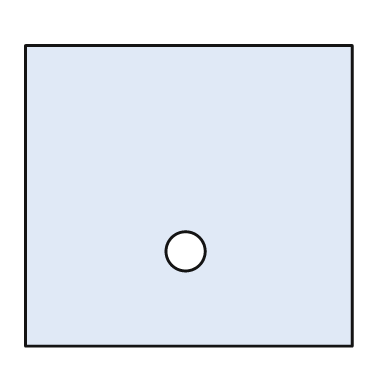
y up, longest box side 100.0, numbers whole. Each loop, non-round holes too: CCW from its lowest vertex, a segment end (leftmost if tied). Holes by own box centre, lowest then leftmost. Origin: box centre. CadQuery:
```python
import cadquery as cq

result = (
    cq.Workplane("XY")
    .moveTo(-50.0, -46.0)
    .lineTo(50.0, -46.0)
    .lineTo(50.0, 46.0)
    .lineTo(-50.0, 46.0)
    .close()
    .moveTo(-1.0, -17.0)
    .circle(6.0)
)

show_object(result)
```